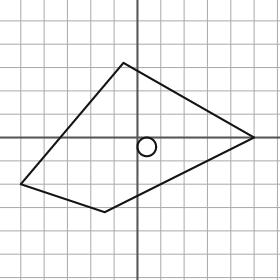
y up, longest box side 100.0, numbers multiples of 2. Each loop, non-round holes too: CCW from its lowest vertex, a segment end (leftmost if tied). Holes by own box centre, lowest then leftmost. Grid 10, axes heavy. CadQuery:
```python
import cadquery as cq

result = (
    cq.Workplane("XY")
    .moveTo(-14.0, -32.0)
    .lineTo(50.0, 0.0)
    .lineTo(-6.0, 32.0)
    .lineTo(-50.0, -20.0)
    .close()
    .moveTo(4.0, -4.0)
    .circle(4.0)
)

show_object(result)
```